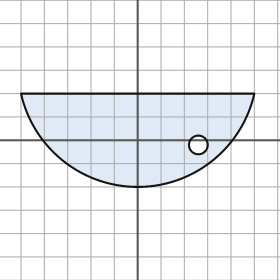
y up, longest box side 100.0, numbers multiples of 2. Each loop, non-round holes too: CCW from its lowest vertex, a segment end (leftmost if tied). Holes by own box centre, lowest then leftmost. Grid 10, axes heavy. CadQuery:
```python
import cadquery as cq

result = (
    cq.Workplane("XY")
    .moveTo(-50.0, 20.0)
    .threePointArc((0.0, -20.0), (50.0, 20.0))
    .close()
    .moveTo(26.0, -2.0)
    .circle(4.0)
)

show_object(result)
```